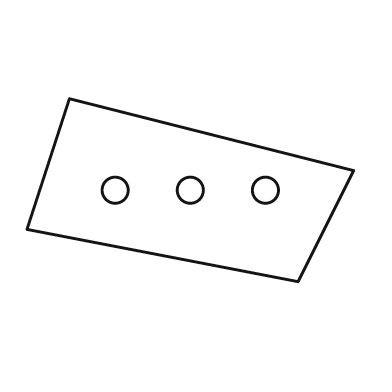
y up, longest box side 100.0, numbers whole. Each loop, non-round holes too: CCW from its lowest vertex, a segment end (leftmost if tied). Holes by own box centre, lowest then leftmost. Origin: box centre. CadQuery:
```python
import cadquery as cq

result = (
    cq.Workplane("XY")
    .moveTo(33.0, -28.0)
    .lineTo(50.0, 6.0)
    .lineTo(-37.0, 28.0)
    .lineTo(-50.0, -12.0)
    .close()
    .moveTo(-23.0, 0.0)
    .circle(4.0)
    .moveTo(0.0, 0.0)
    .circle(4.0)
    .moveTo(23.0, 0.0)
    .circle(4.0)
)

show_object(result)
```